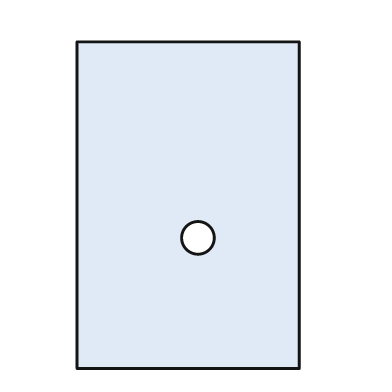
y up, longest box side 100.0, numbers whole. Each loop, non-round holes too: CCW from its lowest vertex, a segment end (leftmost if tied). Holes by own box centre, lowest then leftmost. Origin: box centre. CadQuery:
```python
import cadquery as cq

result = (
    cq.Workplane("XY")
    .moveTo(-34.0, -50.0)
    .lineTo(34.0, -50.0)
    .lineTo(34.0, 50.0)
    .lineTo(-34.0, 50.0)
    .close()
    .moveTo(3.0, -10.0)
    .circle(5.0)
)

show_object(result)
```